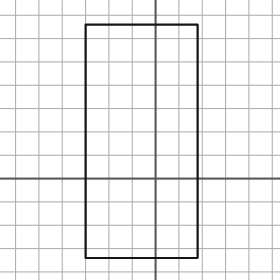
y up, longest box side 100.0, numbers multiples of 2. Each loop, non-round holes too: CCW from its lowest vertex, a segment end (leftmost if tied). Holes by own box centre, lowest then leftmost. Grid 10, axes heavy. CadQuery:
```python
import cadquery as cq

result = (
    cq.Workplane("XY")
    .moveTo(-30.0, -34.0)
    .lineTo(18.0, -34.0)
    .lineTo(18.0, 66.0)
    .lineTo(-30.0, 66.0)
    .close()
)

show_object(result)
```